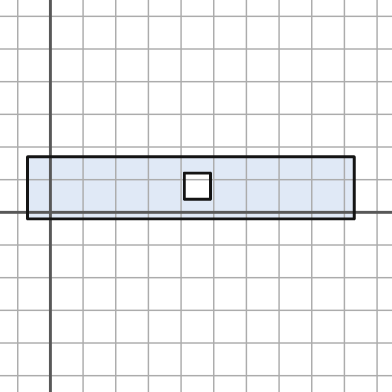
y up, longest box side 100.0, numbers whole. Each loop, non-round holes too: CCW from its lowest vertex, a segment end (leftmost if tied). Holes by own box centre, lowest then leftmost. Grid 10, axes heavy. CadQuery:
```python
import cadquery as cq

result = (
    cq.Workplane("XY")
    .moveTo(-7.0, -2.0)
    .lineTo(93.0, -2.0)
    .lineTo(93.0, 17.0)
    .lineTo(-7.0, 17.0)
    .close()
    .moveTo(41.0, 4.0)
    .lineTo(49.0, 4.0)
    .lineTo(49.0, 12.0)
    .lineTo(41.0, 12.0)
    .close()
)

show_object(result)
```